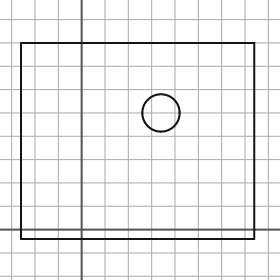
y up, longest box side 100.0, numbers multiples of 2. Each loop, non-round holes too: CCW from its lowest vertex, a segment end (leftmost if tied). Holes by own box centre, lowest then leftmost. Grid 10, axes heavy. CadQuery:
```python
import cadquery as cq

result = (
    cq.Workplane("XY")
    .moveTo(-26.0, -4.0)
    .lineTo(74.0, -4.0)
    .lineTo(74.0, 80.0)
    .lineTo(-26.0, 80.0)
    .close()
    .moveTo(34.0, 50.0)
    .circle(8.0)
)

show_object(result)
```